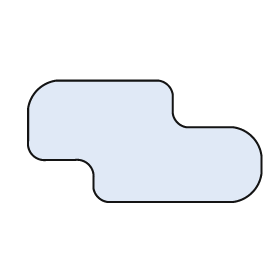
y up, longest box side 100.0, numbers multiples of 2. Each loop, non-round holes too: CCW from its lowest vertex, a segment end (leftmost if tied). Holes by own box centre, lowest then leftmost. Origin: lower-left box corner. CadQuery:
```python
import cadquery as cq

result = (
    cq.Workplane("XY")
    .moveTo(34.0, 0.0)
    .lineTo(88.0, 0.0)
    .threePointArc((96.0, 4.0), (100.0, 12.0))
    .lineTo(100.0, 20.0)
    .threePointArc((96.0, 28.0), (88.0, 32.0))
    .lineTo(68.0, 32.0)
    .threePointArc((64.0, 34.0), (62.0, 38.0))
    .lineTo(62.0, 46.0)
    .threePointArc((60.0, 50.0), (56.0, 52.0))
    .lineTo(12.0, 52.0)
    .threePointArc((4.0, 48.0), (0.0, 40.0))
    .lineTo(0.0, 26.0)
    .threePointArc((2.0, 20.0), (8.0, 18.0))
    .lineTo(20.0, 18.0)
    .threePointArc((26.0, 16.0), (28.0, 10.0))
    .lineTo(28.0, 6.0)
    .threePointArc((30.0, 2.0), (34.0, 0.0))
    .close()
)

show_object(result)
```